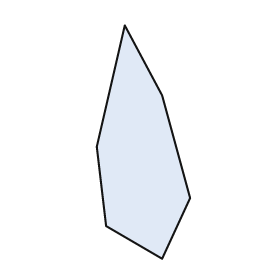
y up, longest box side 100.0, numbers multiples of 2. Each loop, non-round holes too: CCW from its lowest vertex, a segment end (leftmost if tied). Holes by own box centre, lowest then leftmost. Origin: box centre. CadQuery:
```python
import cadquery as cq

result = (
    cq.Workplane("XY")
    .moveTo(8.0, -50.0)
    .lineTo(20.0, -24.0)
    .lineTo(8.0, 20.0)
    .lineTo(-8.0, 50.0)
    .lineTo(-20.0, -2.0)
    .lineTo(-16.0, -36.0)
    .close()
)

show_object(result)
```